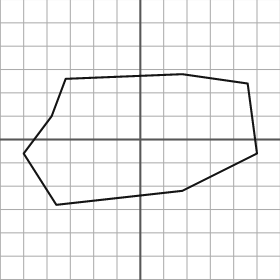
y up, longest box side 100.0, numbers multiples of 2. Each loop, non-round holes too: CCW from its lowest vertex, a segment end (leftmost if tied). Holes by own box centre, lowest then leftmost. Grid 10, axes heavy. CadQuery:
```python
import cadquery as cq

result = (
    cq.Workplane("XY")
    .moveTo(-36.0, -28.0)
    .lineTo(18.0, -22.0)
    .lineTo(50.0, -6.0)
    .lineTo(46.0, 24.0)
    .lineTo(18.0, 28.0)
    .lineTo(-32.0, 26.0)
    .lineTo(-38.0, 10.0)
    .lineTo(-50.0, -6.0)
    .close()
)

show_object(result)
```